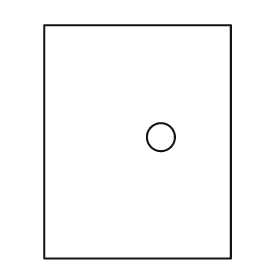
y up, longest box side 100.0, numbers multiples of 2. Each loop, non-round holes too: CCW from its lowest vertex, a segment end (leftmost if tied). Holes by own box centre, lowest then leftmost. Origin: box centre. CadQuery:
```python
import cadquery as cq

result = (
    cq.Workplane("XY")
    .moveTo(-40.0, -50.0)
    .lineTo(40.0, -50.0)
    .lineTo(40.0, 50.0)
    .lineTo(-40.0, 50.0)
    .close()
    .moveTo(10.0, 2.0)
    .circle(6.0)
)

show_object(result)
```